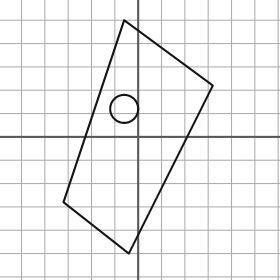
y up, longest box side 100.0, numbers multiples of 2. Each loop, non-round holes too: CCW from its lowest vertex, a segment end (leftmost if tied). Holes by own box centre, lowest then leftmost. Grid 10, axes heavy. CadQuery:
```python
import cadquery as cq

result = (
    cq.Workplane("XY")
    .moveTo(-4.0, -50.0)
    .lineTo(32.0, 22.0)
    .lineTo(-6.0, 50.0)
    .lineTo(-32.0, -28.0)
    .close()
    .moveTo(-6.0, 12.0)
    .circle(6.0)
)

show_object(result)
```